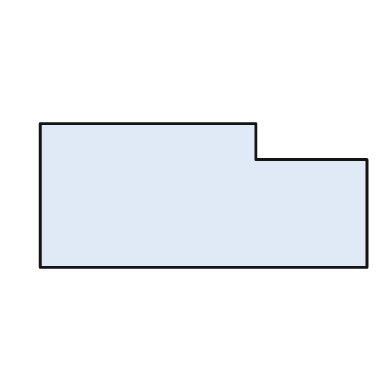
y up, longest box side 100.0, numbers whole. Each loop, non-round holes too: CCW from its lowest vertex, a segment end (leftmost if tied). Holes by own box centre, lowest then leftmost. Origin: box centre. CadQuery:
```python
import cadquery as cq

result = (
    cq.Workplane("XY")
    .moveTo(-50.0, -22.0)
    .lineTo(50.0, -22.0)
    .lineTo(50.0, 11.0)
    .lineTo(16.0, 11.0)
    .lineTo(16.0, 22.0)
    .lineTo(-50.0, 22.0)
    .close()
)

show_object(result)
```